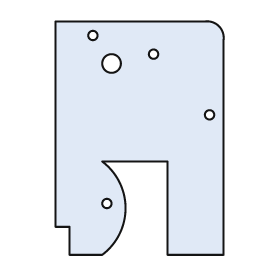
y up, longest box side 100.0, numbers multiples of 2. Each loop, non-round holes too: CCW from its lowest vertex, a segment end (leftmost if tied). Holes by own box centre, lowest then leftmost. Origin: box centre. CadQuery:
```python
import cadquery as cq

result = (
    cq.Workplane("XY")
    .moveTo(-30.0, -50.0)
    .lineTo(-16.0, -50.0)
    .threePointArc((-6.0, -30.0), (-16.0, -10.0))
    .lineTo(12.0, -10.0)
    .lineTo(12.0, -50.0)
    .lineTo(36.0, -50.0)
    .lineTo(36.0, 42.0)
    .threePointArc((34.0, 48.0), (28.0, 50.0))
    .lineTo(-36.0, 50.0)
    .lineTo(-36.0, -38.0)
    .lineTo(-30.0, -38.0)
    .close()
    .moveTo(-14.0, -28.0)
    .circle(2.0)
    .moveTo(30.0, 10.0)
    .circle(2.0)
    .moveTo(-12.0, 32.0)
    .circle(4.0)
    .moveTo(6.0, 36.0)
    .circle(2.0)
    .moveTo(-20.0, 44.0)
    .circle(2.0)
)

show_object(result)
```